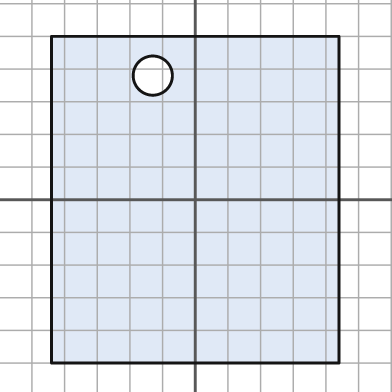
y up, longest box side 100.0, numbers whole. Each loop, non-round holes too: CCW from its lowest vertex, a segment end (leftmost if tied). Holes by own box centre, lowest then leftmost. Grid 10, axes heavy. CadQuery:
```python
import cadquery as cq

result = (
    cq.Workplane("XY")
    .moveTo(-44.0, -50.0)
    .lineTo(44.0, -50.0)
    .lineTo(44.0, 50.0)
    .lineTo(-44.0, 50.0)
    .close()
    .moveTo(-13.0, 38.0)
    .circle(6.0)
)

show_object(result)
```